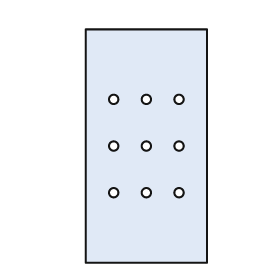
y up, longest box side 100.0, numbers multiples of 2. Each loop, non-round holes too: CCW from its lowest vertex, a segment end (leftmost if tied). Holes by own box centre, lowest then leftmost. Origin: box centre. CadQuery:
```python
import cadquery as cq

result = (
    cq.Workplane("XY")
    .moveTo(-26.0, -50.0)
    .lineTo(26.0, -50.0)
    .lineTo(26.0, 50.0)
    .lineTo(-26.0, 50.0)
    .close()
    .moveTo(-14.0, -20.0)
    .circle(2.0)
    .moveTo(0.0, -20.0)
    .circle(2.0)
    .moveTo(14.0, -20.0)
    .circle(2.0)
    .moveTo(-14.0, 0.0)
    .circle(2.0)
    .moveTo(0.0, 0.0)
    .circle(2.0)
    .moveTo(14.0, 0.0)
    .circle(2.0)
    .moveTo(-14.0, 20.0)
    .circle(2.0)
    .moveTo(0.0, 20.0)
    .circle(2.0)
    .moveTo(14.0, 20.0)
    .circle(2.0)
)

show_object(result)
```